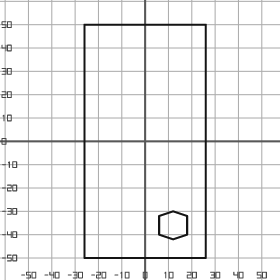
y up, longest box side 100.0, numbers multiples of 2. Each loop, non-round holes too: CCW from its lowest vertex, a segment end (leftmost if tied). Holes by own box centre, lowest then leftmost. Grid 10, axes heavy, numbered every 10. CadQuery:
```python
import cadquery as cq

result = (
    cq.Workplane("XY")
    .moveTo(-26.0, -50.0)
    .lineTo(26.0, -50.0)
    .lineTo(26.0, 50.0)
    .lineTo(-26.0, 50.0)
    .close()
    .moveTo(12.0, -42.0)
    .lineTo(18.0, -40.0)
    .lineTo(18.0, -32.0)
    .lineTo(12.0, -30.0)
    .lineTo(6.0, -32.0)
    .lineTo(6.0, -40.0)
    .close()
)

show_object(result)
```